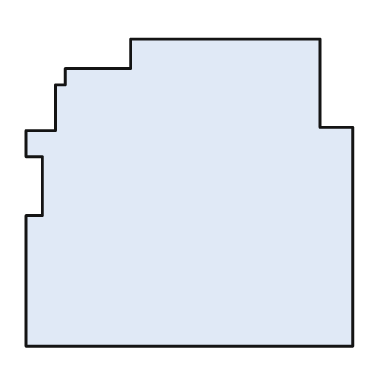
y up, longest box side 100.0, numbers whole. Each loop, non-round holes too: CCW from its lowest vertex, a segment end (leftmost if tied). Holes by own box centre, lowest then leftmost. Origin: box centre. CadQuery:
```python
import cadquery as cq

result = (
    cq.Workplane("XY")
    .moveTo(-50.0, -47.0)
    .lineTo(50.0, -47.0)
    .lineTo(50.0, 20.0)
    .lineTo(40.0, 20.0)
    .lineTo(40.0, 47.0)
    .lineTo(-18.0, 47.0)
    .lineTo(-18.0, 38.0)
    .lineTo(-38.0, 38.0)
    .lineTo(-38.0, 33.0)
    .lineTo(-41.0, 33.0)
    .lineTo(-41.0, 19.0)
    .lineTo(-50.0, 19.0)
    .lineTo(-50.0, 11.0)
    .lineTo(-45.0, 11.0)
    .lineTo(-45.0, -7.0)
    .lineTo(-50.0, -7.0)
    .close()
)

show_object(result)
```